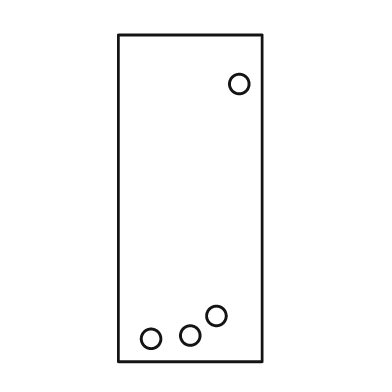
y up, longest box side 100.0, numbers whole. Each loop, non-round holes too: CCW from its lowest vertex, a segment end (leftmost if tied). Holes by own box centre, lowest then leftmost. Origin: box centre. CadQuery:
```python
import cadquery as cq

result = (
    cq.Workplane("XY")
    .moveTo(-22.0, -50.0)
    .lineTo(22.0, -50.0)
    .lineTo(22.0, 50.0)
    .lineTo(-22.0, 50.0)
    .close()
    .moveTo(-12.0, -43.0)
    .circle(3.0)
    .moveTo(0.0, -42.0)
    .circle(3.0)
    .moveTo(8.0, -36.0)
    .circle(3.0)
    .moveTo(15.0, 35.0)
    .circle(3.0)
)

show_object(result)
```